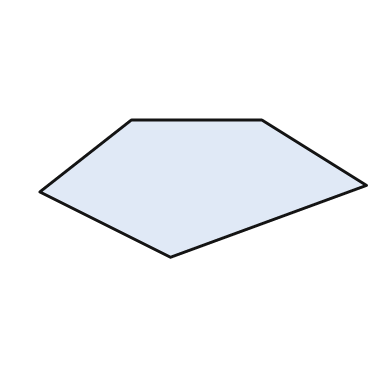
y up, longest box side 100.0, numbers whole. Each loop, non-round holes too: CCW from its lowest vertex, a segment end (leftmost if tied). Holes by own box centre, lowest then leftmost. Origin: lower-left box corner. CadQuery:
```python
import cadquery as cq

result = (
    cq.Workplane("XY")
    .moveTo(40.0, 0.0)
    .lineTo(100.0, 22.0)
    .lineTo(68.0, 42.0)
    .lineTo(28.0, 42.0)
    .lineTo(0.0, 20.0)
    .close()
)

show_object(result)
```